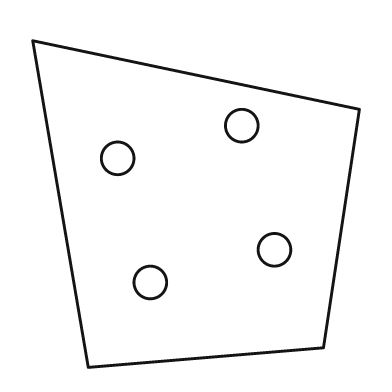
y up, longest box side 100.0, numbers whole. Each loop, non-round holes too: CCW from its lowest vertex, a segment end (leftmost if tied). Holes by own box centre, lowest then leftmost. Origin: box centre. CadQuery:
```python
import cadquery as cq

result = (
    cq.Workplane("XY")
    .moveTo(-33.0, -50.0)
    .lineTo(39.0, -44.0)
    .lineTo(50.0, 29.0)
    .lineTo(-50.0, 50.0)
    .close()
    .moveTo(-14.0, -24.0)
    .circle(5.0)
    .moveTo(24.0, -14.0)
    .circle(5.0)
    .moveTo(-24.0, 14.0)
    .circle(5.0)
    .moveTo(14.0, 24.0)
    .circle(5.0)
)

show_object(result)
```